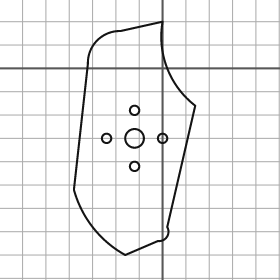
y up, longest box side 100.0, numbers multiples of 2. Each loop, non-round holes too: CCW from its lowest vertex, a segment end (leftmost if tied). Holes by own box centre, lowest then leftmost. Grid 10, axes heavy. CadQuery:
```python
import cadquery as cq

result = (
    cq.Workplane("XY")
    .moveTo(-16.0, -80.0)
    .lineTo(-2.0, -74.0)
    .threePointArc((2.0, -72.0), (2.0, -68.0))
    .lineTo(14.0, -16.0)
    .threePointArc((2.0, 0.0), (0.0, 20.0))
    .lineTo(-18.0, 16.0)
    .threePointArc((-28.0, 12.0), (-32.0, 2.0))
    .lineTo(-38.0, -52.0)
    .threePointArc((-30.0, -68.0), (-16.0, -80.0))
    .close()
    .moveTo(-12.0, -42.0)
    .circle(2.0)
    .moveTo(-24.0, -30.0)
    .circle(2.0)
    .moveTo(-12.0, -30.0)
    .circle(4.0)
    .moveTo(0.0, -30.0)
    .circle(2.0)
    .moveTo(-12.0, -18.0)
    .circle(2.0)
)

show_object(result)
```